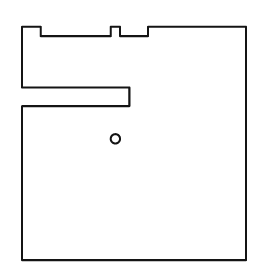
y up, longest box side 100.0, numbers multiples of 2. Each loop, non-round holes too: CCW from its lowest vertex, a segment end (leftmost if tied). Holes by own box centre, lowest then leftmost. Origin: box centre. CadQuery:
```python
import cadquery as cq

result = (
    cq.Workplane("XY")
    .moveTo(-48.0, -50.0)
    .lineTo(48.0, -50.0)
    .lineTo(48.0, 50.0)
    .lineTo(6.0, 50.0)
    .lineTo(6.0, 46.0)
    .lineTo(-6.0, 46.0)
    .lineTo(-6.0, 50.0)
    .lineTo(-10.0, 50.0)
    .lineTo(-10.0, 46.0)
    .lineTo(-40.0, 46.0)
    .lineTo(-40.0, 50.0)
    .lineTo(-48.0, 50.0)
    .lineTo(-48.0, 24.0)
    .lineTo(-2.0, 24.0)
    .lineTo(-2.0, 16.0)
    .lineTo(-48.0, 16.0)
    .close()
    .moveTo(-8.0, 2.0)
    .circle(2.0)
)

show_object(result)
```